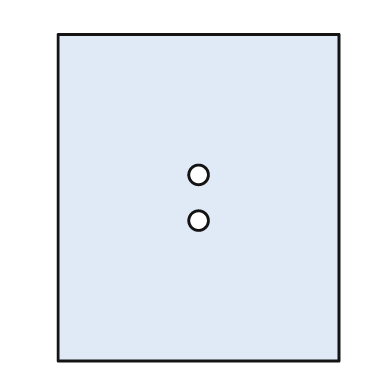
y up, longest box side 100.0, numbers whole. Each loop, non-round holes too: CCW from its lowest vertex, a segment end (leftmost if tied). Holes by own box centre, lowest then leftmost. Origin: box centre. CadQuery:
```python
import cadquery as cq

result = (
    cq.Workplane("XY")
    .moveTo(-43.0, -50.0)
    .lineTo(43.0, -50.0)
    .lineTo(43.0, 50.0)
    .lineTo(-43.0, 50.0)
    .close()
    .moveTo(0.0, -7.0)
    .circle(3.0)
    .moveTo(0.0, 7.0)
    .circle(3.0)
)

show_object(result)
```